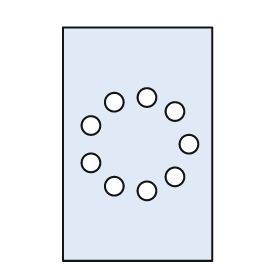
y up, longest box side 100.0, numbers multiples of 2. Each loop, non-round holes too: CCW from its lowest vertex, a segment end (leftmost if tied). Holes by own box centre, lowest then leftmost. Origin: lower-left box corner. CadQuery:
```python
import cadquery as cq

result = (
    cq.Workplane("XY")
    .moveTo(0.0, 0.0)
    .lineTo(64.0, 0.0)
    .lineTo(64.0, 100.0)
    .lineTo(0.0, 100.0)
    .close()
    .moveTo(36.0, 30.0)
    .circle(4.0)
    .moveTo(22.0, 32.0)
    .circle(4.0)
    .moveTo(48.0, 36.0)
    .circle(4.0)
    .moveTo(12.0, 42.0)
    .circle(4.0)
    .moveTo(54.0, 50.0)
    .circle(4.0)
    .moveTo(12.0, 58.0)
    .circle(4.0)
    .moveTo(48.0, 64.0)
    .circle(4.0)
    .moveTo(22.0, 68.0)
    .circle(4.0)
    .moveTo(36.0, 70.0)
    .circle(4.0)
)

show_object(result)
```